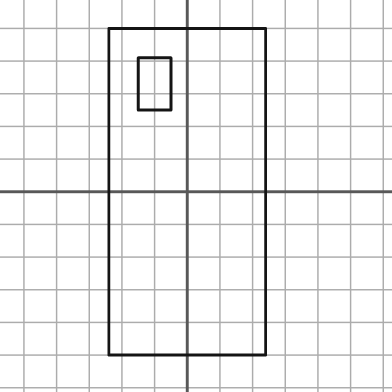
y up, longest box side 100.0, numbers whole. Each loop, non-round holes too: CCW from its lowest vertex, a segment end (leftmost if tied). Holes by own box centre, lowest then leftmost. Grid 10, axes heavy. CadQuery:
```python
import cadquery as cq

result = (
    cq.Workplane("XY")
    .moveTo(-24.0, -50.0)
    .lineTo(24.0, -50.0)
    .lineTo(24.0, 50.0)
    .lineTo(-24.0, 50.0)
    .close()
    .moveTo(-15.0, 25.0)
    .lineTo(-5.0, 25.0)
    .lineTo(-5.0, 41.0)
    .lineTo(-15.0, 41.0)
    .close()
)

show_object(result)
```